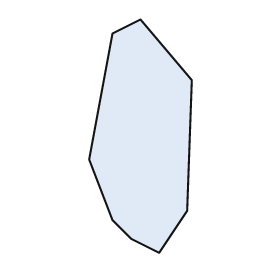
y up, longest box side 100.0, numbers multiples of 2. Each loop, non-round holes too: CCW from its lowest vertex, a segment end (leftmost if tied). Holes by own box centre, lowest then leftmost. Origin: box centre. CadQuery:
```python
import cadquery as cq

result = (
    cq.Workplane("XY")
    .moveTo(8.0, -50.0)
    .lineTo(20.0, -32.0)
    .lineTo(22.0, 24.0)
    .lineTo(0.0, 50.0)
    .lineTo(-12.0, 44.0)
    .lineTo(-22.0, -10.0)
    .lineTo(-12.0, -36.0)
    .lineTo(-4.0, -44.0)
    .close()
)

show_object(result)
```